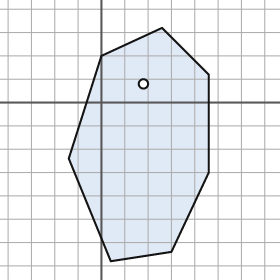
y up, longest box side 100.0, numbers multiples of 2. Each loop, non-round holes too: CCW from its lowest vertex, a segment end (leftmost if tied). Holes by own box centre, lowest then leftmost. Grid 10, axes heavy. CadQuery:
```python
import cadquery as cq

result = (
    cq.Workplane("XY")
    .moveTo(4.0, -68.0)
    .lineTo(30.0, -64.0)
    .lineTo(46.0, -30.0)
    .lineTo(46.0, 12.0)
    .lineTo(26.0, 32.0)
    .lineTo(0.0, 20.0)
    .lineTo(-14.0, -24.0)
    .close()
    .moveTo(18.0, 8.0)
    .circle(2.0)
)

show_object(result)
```